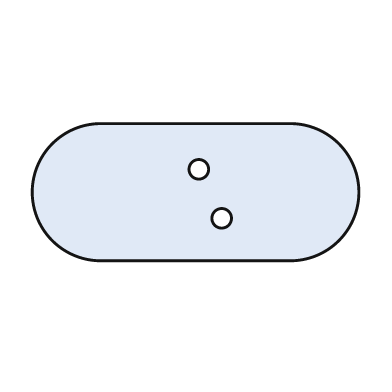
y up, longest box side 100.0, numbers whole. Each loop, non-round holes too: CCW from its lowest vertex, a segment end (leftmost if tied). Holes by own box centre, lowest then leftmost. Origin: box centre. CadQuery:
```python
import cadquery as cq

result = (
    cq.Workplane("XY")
    .moveTo(-29.0, -21.0)
    .lineTo(29.0, -21.0)
    .threePointArc((50.0, 0.0), (29.0, 21.0))
    .lineTo(-29.0, 21.0)
    .threePointArc((-50.0, 0.0), (-29.0, -21.0))
    .close()
    .moveTo(8.0, -8.0)
    .circle(3.0)
    .moveTo(1.0, 7.0)
    .circle(3.0)
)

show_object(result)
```